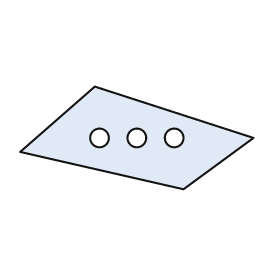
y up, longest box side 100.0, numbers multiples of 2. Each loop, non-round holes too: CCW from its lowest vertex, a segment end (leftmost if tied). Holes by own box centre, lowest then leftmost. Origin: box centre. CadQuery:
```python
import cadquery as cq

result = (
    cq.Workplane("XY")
    .moveTo(20.0, -22.0)
    .lineTo(50.0, 0.0)
    .lineTo(-18.0, 22.0)
    .lineTo(-50.0, -6.0)
    .close()
    .moveTo(-16.0, 0.0)
    .circle(4.0)
    .moveTo(0.0, 0.0)
    .circle(4.0)
    .moveTo(16.0, 0.0)
    .circle(4.0)
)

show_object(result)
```